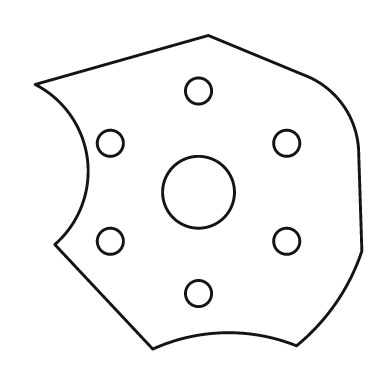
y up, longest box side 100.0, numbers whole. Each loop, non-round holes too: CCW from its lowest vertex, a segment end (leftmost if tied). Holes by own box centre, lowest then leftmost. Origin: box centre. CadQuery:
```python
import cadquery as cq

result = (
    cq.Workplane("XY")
    .moveTo(-14.0, -48.0)
    .threePointArc((8.0, -43.0), (30.0, -47.0))
    .threePointArc((42.0, -34.0), (50.0, -18.0))
    .lineTo(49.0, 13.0)
    .threePointArc((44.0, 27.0), (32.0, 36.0))
    .lineTo(3.0, 48.0)
    .lineTo(-50.0, 33.0)
    .threePointArc((-34.0, 10.0), (-44.0, -16.0))
    .close()
    .moveTo(0.0, -31.0)
    .circle(4.0)
    .moveTo(-27.0, -15.0)
    .circle(4.0)
    .moveTo(27.0, -15.0)
    .circle(4.0)
    .moveTo(0.0, 0.0)
    .circle(11.0)
    .moveTo(-27.0, 15.0)
    .circle(4.0)
    .moveTo(27.0, 15.0)
    .circle(4.0)
    .moveTo(0.0, 31.0)
    .circle(4.0)
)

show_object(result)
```